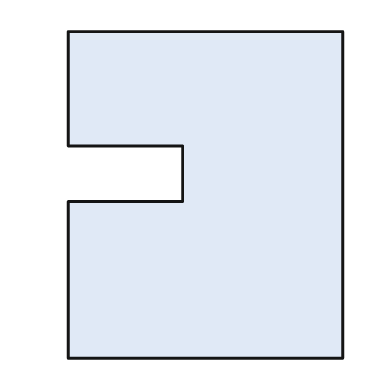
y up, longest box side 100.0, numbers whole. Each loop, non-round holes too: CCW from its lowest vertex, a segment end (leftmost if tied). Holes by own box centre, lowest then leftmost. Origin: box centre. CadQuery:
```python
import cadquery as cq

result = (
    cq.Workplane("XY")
    .moveTo(-42.0, -50.0)
    .lineTo(42.0, -50.0)
    .lineTo(42.0, 50.0)
    .lineTo(-42.0, 50.0)
    .lineTo(-42.0, 15.0)
    .lineTo(-7.0, 15.0)
    .lineTo(-7.0, -2.0)
    .lineTo(-42.0, -2.0)
    .close()
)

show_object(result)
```